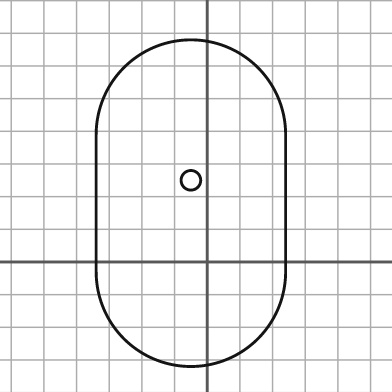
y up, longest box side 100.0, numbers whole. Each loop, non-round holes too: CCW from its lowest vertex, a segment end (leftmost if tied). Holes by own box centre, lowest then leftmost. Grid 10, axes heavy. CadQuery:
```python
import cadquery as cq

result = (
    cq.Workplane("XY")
    .moveTo(-34.0, -3.0)
    .threePointArc((-5.0, -32.0), (24.0, -3.0))
    .lineTo(24.0, 39.0)
    .threePointArc((-5.0, 68.0), (-34.0, 39.0))
    .close()
    .moveTo(-5.0, 25.0)
    .circle(3.0)
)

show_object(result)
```